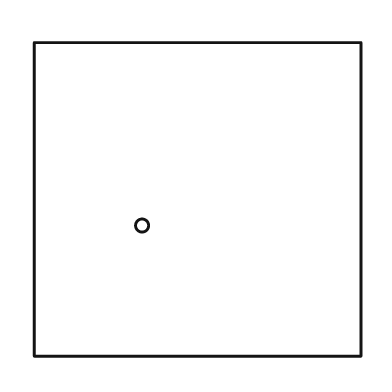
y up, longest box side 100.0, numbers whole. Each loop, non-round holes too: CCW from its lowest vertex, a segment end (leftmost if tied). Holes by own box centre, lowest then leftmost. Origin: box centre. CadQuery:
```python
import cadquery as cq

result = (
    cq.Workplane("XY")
    .moveTo(-50.0, -48.0)
    .lineTo(50.0, -48.0)
    .lineTo(50.0, 48.0)
    .lineTo(-50.0, 48.0)
    .close()
    .moveTo(-17.0, -8.0)
    .circle(2.0)
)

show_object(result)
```